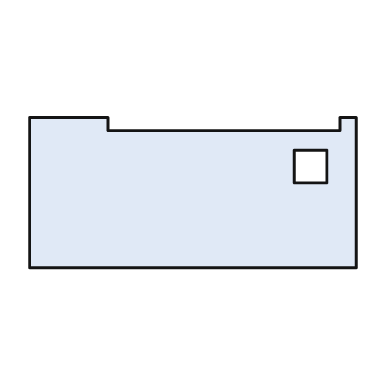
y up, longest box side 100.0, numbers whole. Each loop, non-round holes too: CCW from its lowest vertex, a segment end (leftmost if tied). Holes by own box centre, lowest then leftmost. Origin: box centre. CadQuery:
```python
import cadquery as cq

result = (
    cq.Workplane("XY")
    .moveTo(-50.0, -23.0)
    .lineTo(50.0, -23.0)
    .lineTo(50.0, 23.0)
    .lineTo(45.0, 23.0)
    .lineTo(45.0, 19.0)
    .lineTo(-26.0, 19.0)
    .lineTo(-26.0, 23.0)
    .lineTo(-50.0, 23.0)
    .close()
    .moveTo(31.0, 3.0)
    .lineTo(41.0, 3.0)
    .lineTo(41.0, 13.0)
    .lineTo(31.0, 13.0)
    .close()
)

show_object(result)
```